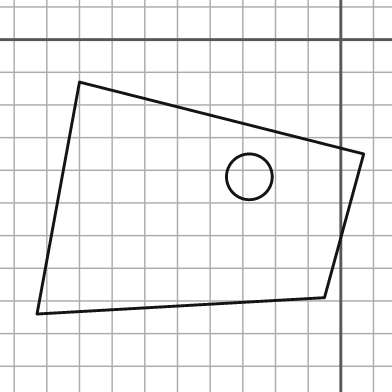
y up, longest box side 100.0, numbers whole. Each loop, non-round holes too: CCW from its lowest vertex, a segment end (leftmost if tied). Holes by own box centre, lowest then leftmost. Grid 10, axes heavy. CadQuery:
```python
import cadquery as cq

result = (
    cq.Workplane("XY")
    .moveTo(-93.0, -84.0)
    .lineTo(-5.0, -79.0)
    .lineTo(7.0, -35.0)
    .lineTo(-80.0, -13.0)
    .close()
    .moveTo(-28.0, -42.0)
    .circle(7.0)
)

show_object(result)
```